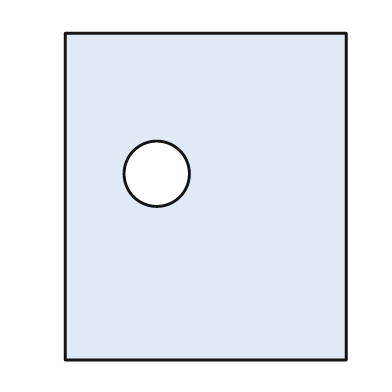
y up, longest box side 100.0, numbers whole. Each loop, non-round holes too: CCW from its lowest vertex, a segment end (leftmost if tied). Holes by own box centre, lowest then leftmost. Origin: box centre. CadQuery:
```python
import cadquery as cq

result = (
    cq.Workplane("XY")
    .moveTo(-43.0, -50.0)
    .lineTo(43.0, -50.0)
    .lineTo(43.0, 50.0)
    .lineTo(-43.0, 50.0)
    .close()
    .moveTo(-15.0, 7.0)
    .circle(10.0)
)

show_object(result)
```